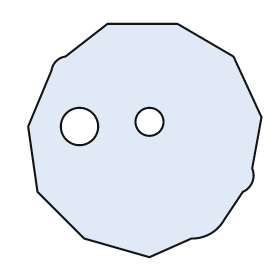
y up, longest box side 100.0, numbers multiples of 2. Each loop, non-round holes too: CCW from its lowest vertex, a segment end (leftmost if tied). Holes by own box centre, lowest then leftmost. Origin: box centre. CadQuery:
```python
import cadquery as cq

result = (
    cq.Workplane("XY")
    .moveTo(2.0, -50.0)
    .lineTo(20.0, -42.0)
    .threePointArc((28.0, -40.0), (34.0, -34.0))
    .lineTo(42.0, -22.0)
    .threePointArc((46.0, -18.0), (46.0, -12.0))
    .lineTo(50.0, 10.0)
    .lineTo(38.0, 36.0)
    .lineTo(14.0, 50.0)
    .lineTo(-16.0, 50.0)
    .lineTo(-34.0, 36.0)
    .threePointArc((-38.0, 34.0), (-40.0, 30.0))
    .lineTo(-50.0, 6.0)
    .lineTo(-46.0, -22.0)
    .lineTo(-26.0, -42.0)
    .close()
    .moveTo(-28.0, 6.0)
    .circle(8.0)
    .moveTo(2.0, 8.0)
    .circle(6.0)
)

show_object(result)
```